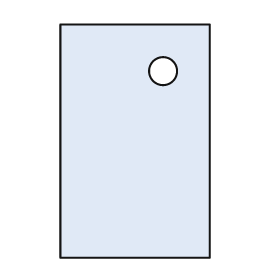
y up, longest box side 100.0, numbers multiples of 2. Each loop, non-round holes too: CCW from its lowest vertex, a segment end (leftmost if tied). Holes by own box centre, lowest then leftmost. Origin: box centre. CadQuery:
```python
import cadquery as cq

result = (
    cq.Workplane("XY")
    .moveTo(-32.0, -50.0)
    .lineTo(32.0, -50.0)
    .lineTo(32.0, 50.0)
    .lineTo(-32.0, 50.0)
    .close()
    .moveTo(12.0, 30.0)
    .circle(6.0)
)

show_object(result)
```